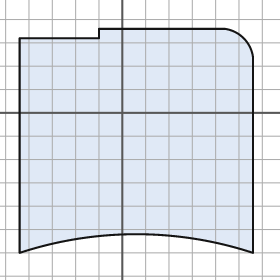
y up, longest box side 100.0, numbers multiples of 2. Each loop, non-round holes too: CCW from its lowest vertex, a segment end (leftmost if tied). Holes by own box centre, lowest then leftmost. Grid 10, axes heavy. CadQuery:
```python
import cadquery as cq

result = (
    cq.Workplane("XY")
    .moveTo(-44.0, -60.0)
    .threePointArc((6.0, -52.0), (56.0, -60.0))
    .lineTo(56.0, 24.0)
    .threePointArc((52.0, 32.0), (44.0, 36.0))
    .lineTo(-10.0, 36.0)
    .lineTo(-10.0, 32.0)
    .lineTo(-44.0, 32.0)
    .close()
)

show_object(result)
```